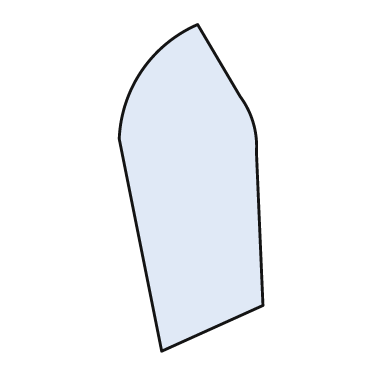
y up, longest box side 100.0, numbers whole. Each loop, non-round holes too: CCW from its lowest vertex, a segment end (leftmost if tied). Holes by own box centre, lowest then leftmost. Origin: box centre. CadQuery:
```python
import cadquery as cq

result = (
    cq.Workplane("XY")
    .moveTo(-9.0, -50.0)
    .lineTo(22.0, -36.0)
    .lineTo(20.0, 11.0)
    .threePointArc((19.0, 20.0), (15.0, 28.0))
    .lineTo(2.0, 50.0)
    .threePointArc((-15.0, 36.0), (-22.0, 15.0))
    .close()
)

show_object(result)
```